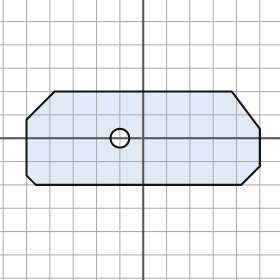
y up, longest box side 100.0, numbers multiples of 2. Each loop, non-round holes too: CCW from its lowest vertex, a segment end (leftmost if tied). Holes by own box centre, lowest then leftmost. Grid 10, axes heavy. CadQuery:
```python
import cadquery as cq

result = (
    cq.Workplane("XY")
    .moveTo(-46.0, -20.0)
    .lineTo(42.0, -20.0)
    .lineTo(50.0, -12.0)
    .lineTo(50.0, 4.0)
    .lineTo(38.0, 20.0)
    .lineTo(-38.0, 20.0)
    .lineTo(-50.0, 8.0)
    .lineTo(-50.0, -16.0)
    .close()
    .moveTo(-10.0, 0.0)
    .circle(4.0)
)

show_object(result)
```